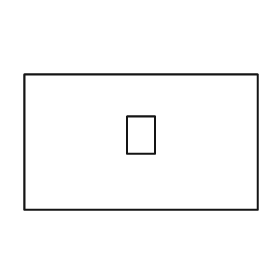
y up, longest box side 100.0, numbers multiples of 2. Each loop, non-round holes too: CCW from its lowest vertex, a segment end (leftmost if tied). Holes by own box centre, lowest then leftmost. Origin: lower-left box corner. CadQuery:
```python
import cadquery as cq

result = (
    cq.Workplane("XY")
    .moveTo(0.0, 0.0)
    .lineTo(100.0, 0.0)
    .lineTo(100.0, 58.0)
    .lineTo(0.0, 58.0)
    .close()
    .moveTo(44.0, 24.0)
    .lineTo(56.0, 24.0)
    .lineTo(56.0, 40.0)
    .lineTo(44.0, 40.0)
    .close()
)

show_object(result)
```